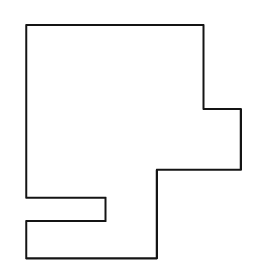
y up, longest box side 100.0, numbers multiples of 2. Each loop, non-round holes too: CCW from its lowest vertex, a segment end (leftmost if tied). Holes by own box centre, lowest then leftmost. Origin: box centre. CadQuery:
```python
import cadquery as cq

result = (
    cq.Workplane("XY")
    .moveTo(-46.0, -50.0)
    .lineTo(10.0, -50.0)
    .lineTo(10.0, -12.0)
    .lineTo(46.0, -12.0)
    .lineTo(46.0, 14.0)
    .lineTo(30.0, 14.0)
    .lineTo(30.0, 50.0)
    .lineTo(-46.0, 50.0)
    .lineTo(-46.0, -24.0)
    .lineTo(-12.0, -24.0)
    .lineTo(-12.0, -34.0)
    .lineTo(-46.0, -34.0)
    .close()
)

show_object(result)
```